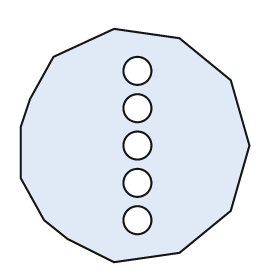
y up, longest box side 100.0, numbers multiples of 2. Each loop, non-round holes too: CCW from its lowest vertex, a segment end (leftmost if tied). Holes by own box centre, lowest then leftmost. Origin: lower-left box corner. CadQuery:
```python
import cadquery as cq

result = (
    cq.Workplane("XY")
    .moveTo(40.0, 0.0)
    .lineTo(68.0, 4.0)
    .lineTo(90.0, 22.0)
    .lineTo(98.0, 50.0)
    .lineTo(90.0, 78.0)
    .lineTo(68.0, 96.0)
    .lineTo(40.0, 100.0)
    .lineTo(14.0, 88.0)
    .lineTo(4.0, 70.0)
    .lineTo(0.0, 58.0)
    .lineTo(0.0, 36.0)
    .lineTo(10.0, 18.0)
    .lineTo(20.0, 10.0)
    .close()
    .moveTo(50.0, 18.0)
    .circle(6.0)
    .moveTo(50.0, 34.0)
    .circle(6.0)
    .moveTo(50.0, 50.0)
    .circle(6.0)
    .moveTo(50.0, 66.0)
    .circle(6.0)
    .moveTo(50.0, 82.0)
    .circle(6.0)
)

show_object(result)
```